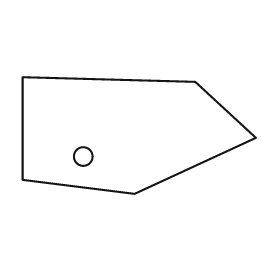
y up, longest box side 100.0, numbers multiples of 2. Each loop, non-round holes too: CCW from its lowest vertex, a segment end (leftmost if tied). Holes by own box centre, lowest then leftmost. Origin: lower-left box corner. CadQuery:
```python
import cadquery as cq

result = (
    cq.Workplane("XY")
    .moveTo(48.0, 0.0)
    .lineTo(100.0, 24.0)
    .lineTo(74.0, 48.0)
    .lineTo(0.0, 50.0)
    .lineTo(0.0, 6.0)
    .close()
    .moveTo(26.0, 16.0)
    .circle(4.0)
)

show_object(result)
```